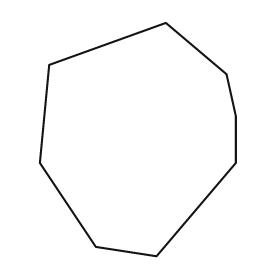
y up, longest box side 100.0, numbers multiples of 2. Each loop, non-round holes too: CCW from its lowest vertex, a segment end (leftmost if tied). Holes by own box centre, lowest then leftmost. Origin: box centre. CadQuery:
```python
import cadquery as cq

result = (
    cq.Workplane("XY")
    .moveTo(8.0, -50.0)
    .lineTo(42.0, -10.0)
    .lineTo(42.0, 10.0)
    .lineTo(38.0, 28.0)
    .lineTo(12.0, 50.0)
    .lineTo(-38.0, 32.0)
    .lineTo(-42.0, -10.0)
    .lineTo(-18.0, -46.0)
    .close()
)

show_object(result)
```